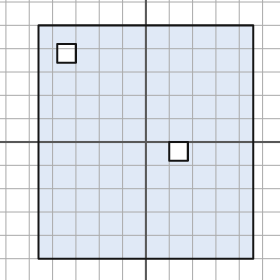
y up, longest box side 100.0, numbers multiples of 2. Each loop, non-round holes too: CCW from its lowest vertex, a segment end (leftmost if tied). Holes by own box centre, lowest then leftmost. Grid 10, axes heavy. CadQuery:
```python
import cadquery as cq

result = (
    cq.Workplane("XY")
    .moveTo(-46.0, -50.0)
    .lineTo(46.0, -50.0)
    .lineTo(46.0, 50.0)
    .lineTo(-46.0, 50.0)
    .close()
    .moveTo(10.0, -8.0)
    .lineTo(18.0, -8.0)
    .lineTo(18.0, 0.0)
    .lineTo(10.0, 0.0)
    .close()
    .moveTo(-38.0, 34.0)
    .lineTo(-30.0, 34.0)
    .lineTo(-30.0, 42.0)
    .lineTo(-38.0, 42.0)
    .close()
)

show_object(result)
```